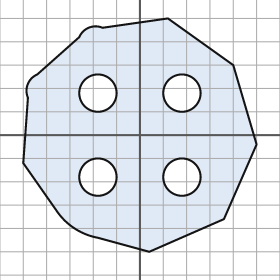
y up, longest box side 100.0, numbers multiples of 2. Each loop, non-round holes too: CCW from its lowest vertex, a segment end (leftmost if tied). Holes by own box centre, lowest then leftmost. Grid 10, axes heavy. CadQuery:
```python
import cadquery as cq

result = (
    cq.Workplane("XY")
    .moveTo(4.0, -50.0)
    .lineTo(36.0, -36.0)
    .lineTo(50.0, -4.0)
    .lineTo(40.0, 30.0)
    .lineTo(12.0, 50.0)
    .lineTo(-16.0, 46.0)
    .threePointArc((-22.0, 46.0), (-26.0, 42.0))
    .lineTo(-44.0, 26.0)
    .threePointArc((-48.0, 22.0), (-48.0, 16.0))
    .lineTo(-50.0, -12.0)
    .lineTo(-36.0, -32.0)
    .threePointArc((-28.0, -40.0), (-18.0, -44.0))
    .close()
    .moveTo(-18.0, -18.0)
    .circle(8.0)
    .moveTo(18.0, -18.0)
    .circle(8.0)
    .moveTo(-18.0, 18.0)
    .circle(8.0)
    .moveTo(18.0, 18.0)
    .circle(8.0)
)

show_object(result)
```